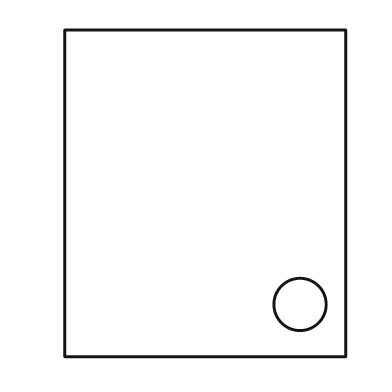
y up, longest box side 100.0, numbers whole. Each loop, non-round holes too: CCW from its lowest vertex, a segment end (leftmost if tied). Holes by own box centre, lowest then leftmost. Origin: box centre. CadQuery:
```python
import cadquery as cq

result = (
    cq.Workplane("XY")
    .moveTo(-43.0, -50.0)
    .lineTo(43.0, -50.0)
    .lineTo(43.0, 50.0)
    .lineTo(-43.0, 50.0)
    .close()
    .moveTo(29.0, -34.0)
    .circle(8.0)
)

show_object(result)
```